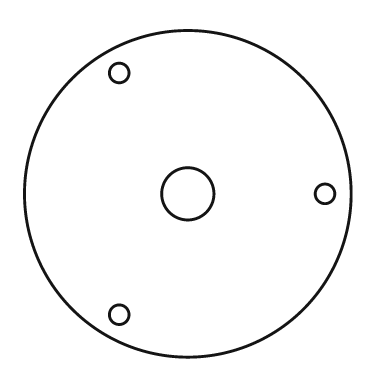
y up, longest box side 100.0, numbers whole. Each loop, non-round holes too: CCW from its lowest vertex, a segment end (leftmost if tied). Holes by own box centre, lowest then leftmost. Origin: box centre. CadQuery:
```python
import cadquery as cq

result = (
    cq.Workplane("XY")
    .moveTo(0.0, 0.0)
    .circle(50.0)
    .moveTo(-21.0, -37.0)
    .circle(3.0)
    .moveTo(0.0, 0.0)
    .circle(8.0)
    .moveTo(42.0, 0.0)
    .circle(3.0)
    .moveTo(-21.0, 37.0)
    .circle(3.0)
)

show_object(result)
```